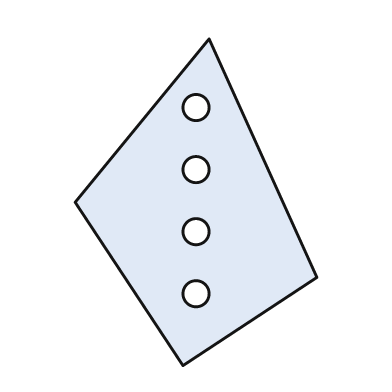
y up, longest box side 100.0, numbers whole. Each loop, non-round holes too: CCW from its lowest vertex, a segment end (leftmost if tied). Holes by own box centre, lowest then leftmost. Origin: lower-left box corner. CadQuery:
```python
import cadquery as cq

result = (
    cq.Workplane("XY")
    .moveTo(33.0, 0.0)
    .lineTo(74.0, 27.0)
    .lineTo(41.0, 100.0)
    .lineTo(0.0, 50.0)
    .close()
    .moveTo(37.0, 22.0)
    .circle(4.0)
    .moveTo(37.0, 41.0)
    .circle(4.0)
    .moveTo(37.0, 60.0)
    .circle(4.0)
    .moveTo(37.0, 79.0)
    .circle(4.0)
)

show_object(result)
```